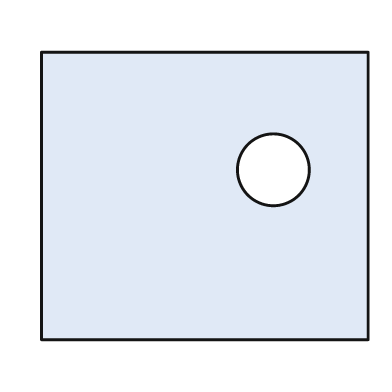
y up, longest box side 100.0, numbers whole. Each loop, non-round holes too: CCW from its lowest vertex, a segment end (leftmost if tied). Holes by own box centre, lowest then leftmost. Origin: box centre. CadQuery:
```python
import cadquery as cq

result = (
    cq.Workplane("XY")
    .moveTo(-50.0, -44.0)
    .lineTo(50.0, -44.0)
    .lineTo(50.0, 44.0)
    .lineTo(-50.0, 44.0)
    .close()
    .moveTo(21.0, 8.0)
    .circle(11.0)
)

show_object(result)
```